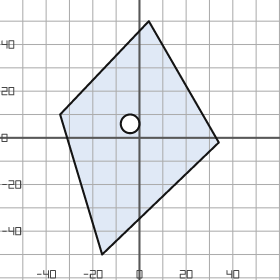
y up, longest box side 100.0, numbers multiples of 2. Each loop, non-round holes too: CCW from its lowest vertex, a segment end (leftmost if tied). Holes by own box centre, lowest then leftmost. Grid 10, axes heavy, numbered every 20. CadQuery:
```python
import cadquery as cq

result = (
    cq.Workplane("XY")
    .moveTo(-16.0, -50.0)
    .lineTo(34.0, -2.0)
    .lineTo(4.0, 50.0)
    .lineTo(-34.0, 10.0)
    .close()
    .moveTo(-4.0, 6.0)
    .circle(4.0)
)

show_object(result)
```